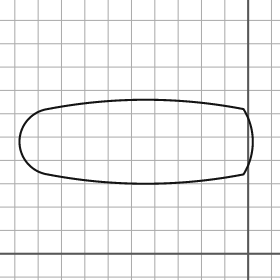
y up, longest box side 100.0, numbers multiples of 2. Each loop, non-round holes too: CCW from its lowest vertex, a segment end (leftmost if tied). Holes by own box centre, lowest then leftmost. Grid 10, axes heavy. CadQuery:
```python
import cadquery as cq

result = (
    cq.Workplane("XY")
    .moveTo(-86.0, 34.0)
    .threePointArc((-44.0, 30.0), (-2.0, 34.0))
    .threePointArc((2.0, 48.0), (-2.0, 62.0))
    .threePointArc((-44.0, 66.0), (-86.0, 62.0))
    .threePointArc((-98.0, 48.0), (-86.0, 34.0))
    .close()
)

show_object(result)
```